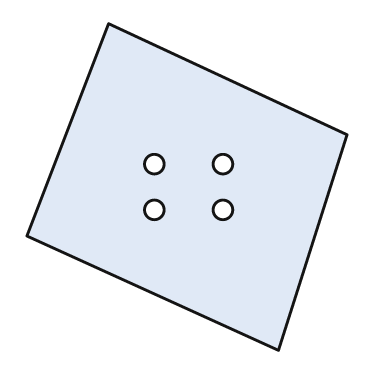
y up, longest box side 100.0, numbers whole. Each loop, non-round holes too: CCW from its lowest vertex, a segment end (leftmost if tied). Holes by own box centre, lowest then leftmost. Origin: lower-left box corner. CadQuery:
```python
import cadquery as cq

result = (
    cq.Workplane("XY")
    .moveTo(77.0, 0.0)
    .lineTo(98.0, 66.0)
    .lineTo(25.0, 100.0)
    .lineTo(0.0, 35.0)
    .close()
    .moveTo(39.0, 43.0)
    .circle(3.0)
    .moveTo(60.0, 43.0)
    .circle(3.0)
    .moveTo(39.0, 57.0)
    .circle(3.0)
    .moveTo(60.0, 57.0)
    .circle(3.0)
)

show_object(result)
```